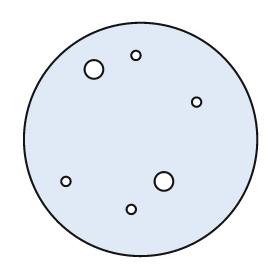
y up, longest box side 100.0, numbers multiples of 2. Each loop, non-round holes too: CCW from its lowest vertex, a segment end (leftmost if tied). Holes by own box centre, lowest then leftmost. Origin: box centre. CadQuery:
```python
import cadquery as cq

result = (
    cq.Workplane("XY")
    .moveTo(0.0, 0.0)
    .circle(50.0)
    .moveTo(-4.0, -30.0)
    .circle(2.0)
    .moveTo(-32.0, -18.0)
    .circle(2.0)
    .moveTo(10.0, -18.0)
    .circle(4.0)
    .moveTo(24.0, 16.0)
    .circle(2.0)
    .moveTo(-20.0, 30.0)
    .circle(4.0)
    .moveTo(-2.0, 36.0)
    .circle(2.0)
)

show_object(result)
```